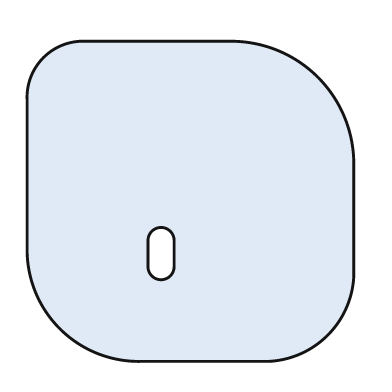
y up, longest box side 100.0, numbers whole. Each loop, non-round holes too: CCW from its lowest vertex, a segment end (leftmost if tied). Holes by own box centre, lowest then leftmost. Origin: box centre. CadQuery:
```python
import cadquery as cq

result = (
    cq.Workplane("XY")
    .moveTo(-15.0, -49.0)
    .lineTo(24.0, -49.0)
    .threePointArc((42.0, -41.0), (50.0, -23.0))
    .lineTo(50.0, 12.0)
    .threePointArc((39.0, 38.0), (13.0, 49.0))
    .lineTo(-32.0, 49.0)
    .threePointArc((-45.0, 44.0), (-50.0, 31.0))
    .lineTo(-50.0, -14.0)
    .threePointArc((-40.0, -39.0), (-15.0, -49.0))
    .close()
    .moveTo(-13.0, -20.0)
    .threePointArc((-9.0, -24.0), (-5.0, -20.0))
    .lineTo(-5.0, -12.0)
    .threePointArc((-9.0, -8.0), (-13.0, -12.0))
    .close()
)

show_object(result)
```